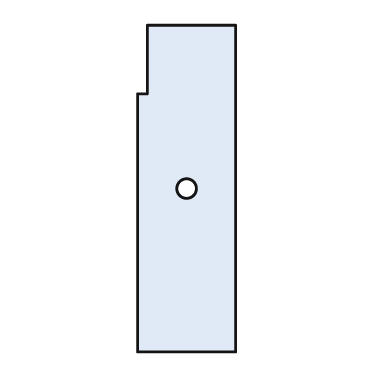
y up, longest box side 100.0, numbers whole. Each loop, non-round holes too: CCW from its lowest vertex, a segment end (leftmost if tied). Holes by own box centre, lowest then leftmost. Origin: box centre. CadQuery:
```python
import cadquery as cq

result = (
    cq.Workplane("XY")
    .moveTo(-15.0, -50.0)
    .lineTo(15.0, -50.0)
    .lineTo(15.0, 50.0)
    .lineTo(-12.0, 50.0)
    .lineTo(-12.0, 29.0)
    .lineTo(-15.0, 29.0)
    .close()
    .moveTo(0.0, 0.0)
    .circle(3.0)
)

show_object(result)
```